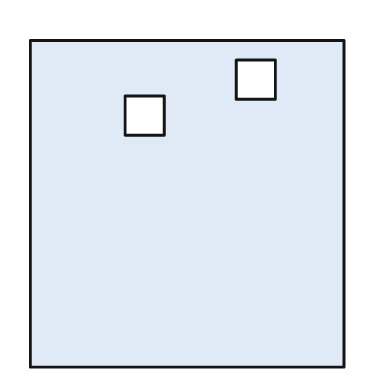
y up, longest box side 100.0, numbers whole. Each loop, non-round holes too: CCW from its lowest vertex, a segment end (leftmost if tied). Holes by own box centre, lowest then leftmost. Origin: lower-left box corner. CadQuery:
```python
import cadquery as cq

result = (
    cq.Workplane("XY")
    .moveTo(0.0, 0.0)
    .lineTo(96.0, 0.0)
    .lineTo(96.0, 100.0)
    .lineTo(0.0, 100.0)
    .close()
    .moveTo(29.0, 71.0)
    .lineTo(41.0, 71.0)
    .lineTo(41.0, 83.0)
    .lineTo(29.0, 83.0)
    .close()
    .moveTo(63.0, 82.0)
    .lineTo(75.0, 82.0)
    .lineTo(75.0, 94.0)
    .lineTo(63.0, 94.0)
    .close()
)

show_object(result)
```